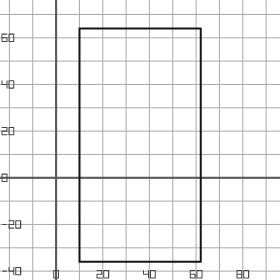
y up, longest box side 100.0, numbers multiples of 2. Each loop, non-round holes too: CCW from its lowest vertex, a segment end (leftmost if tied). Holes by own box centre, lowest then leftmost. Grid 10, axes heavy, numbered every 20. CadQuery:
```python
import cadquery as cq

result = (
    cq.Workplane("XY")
    .moveTo(10.0, -36.0)
    .lineTo(62.0, -36.0)
    .lineTo(62.0, 64.0)
    .lineTo(10.0, 64.0)
    .close()
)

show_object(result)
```